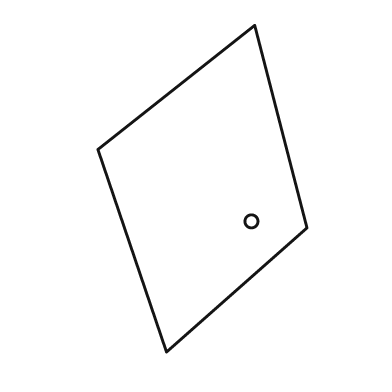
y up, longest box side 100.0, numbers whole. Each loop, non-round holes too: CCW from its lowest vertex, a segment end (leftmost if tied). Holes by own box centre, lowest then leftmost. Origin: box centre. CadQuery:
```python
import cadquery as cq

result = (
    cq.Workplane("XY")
    .moveTo(-11.0, -50.0)
    .lineTo(32.0, -12.0)
    .lineTo(16.0, 50.0)
    .lineTo(-32.0, 12.0)
    .close()
    .moveTo(15.0, -10.0)
    .circle(2.0)
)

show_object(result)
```